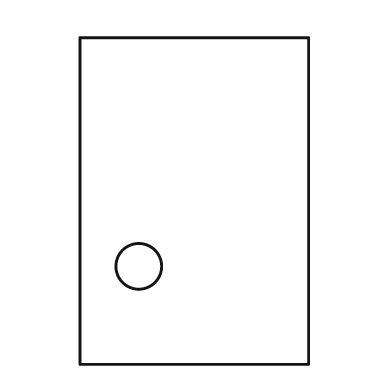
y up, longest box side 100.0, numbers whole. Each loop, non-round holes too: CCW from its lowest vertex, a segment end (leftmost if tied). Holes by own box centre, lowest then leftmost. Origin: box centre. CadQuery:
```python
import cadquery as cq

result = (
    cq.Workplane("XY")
    .moveTo(-35.0, -50.0)
    .lineTo(35.0, -50.0)
    .lineTo(35.0, 50.0)
    .lineTo(-35.0, 50.0)
    .close()
    .moveTo(-17.0, -20.0)
    .circle(7.0)
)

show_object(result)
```